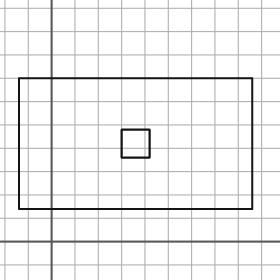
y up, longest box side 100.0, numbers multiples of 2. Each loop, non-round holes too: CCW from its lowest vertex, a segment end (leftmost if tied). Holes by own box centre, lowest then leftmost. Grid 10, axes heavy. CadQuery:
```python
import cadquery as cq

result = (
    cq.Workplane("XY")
    .moveTo(-14.0, 14.0)
    .lineTo(86.0, 14.0)
    .lineTo(86.0, 70.0)
    .lineTo(-14.0, 70.0)
    .close()
    .moveTo(30.0, 36.0)
    .lineTo(42.0, 36.0)
    .lineTo(42.0, 48.0)
    .lineTo(30.0, 48.0)
    .close()
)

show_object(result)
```